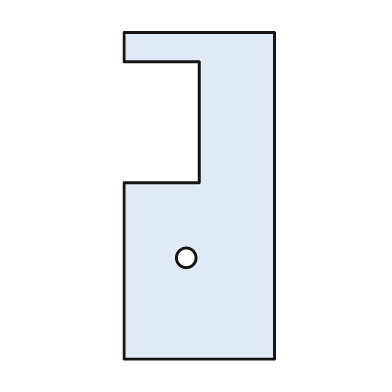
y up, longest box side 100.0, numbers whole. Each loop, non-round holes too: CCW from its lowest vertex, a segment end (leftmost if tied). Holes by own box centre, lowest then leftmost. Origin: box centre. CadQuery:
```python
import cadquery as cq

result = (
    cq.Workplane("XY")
    .moveTo(-23.0, -50.0)
    .lineTo(23.0, -50.0)
    .lineTo(23.0, 50.0)
    .lineTo(-23.0, 50.0)
    .lineTo(-23.0, 41.0)
    .lineTo(0.0, 41.0)
    .lineTo(0.0, 4.0)
    .lineTo(-23.0, 4.0)
    .close()
    .moveTo(-4.0, -19.0)
    .circle(3.0)
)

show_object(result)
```